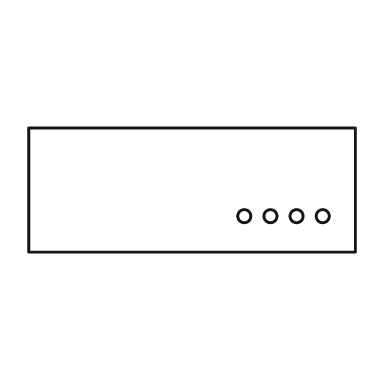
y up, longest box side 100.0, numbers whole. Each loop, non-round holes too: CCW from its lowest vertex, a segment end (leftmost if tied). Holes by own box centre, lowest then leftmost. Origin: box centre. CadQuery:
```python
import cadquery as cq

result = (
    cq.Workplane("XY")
    .moveTo(-50.0, -19.0)
    .lineTo(50.0, -19.0)
    .lineTo(50.0, 19.0)
    .lineTo(-50.0, 19.0)
    .close()
    .moveTo(16.0, -8.0)
    .circle(2.0)
    .moveTo(24.0, -8.0)
    .circle(2.0)
    .moveTo(32.0, -8.0)
    .circle(2.0)
    .moveTo(40.0, -8.0)
    .circle(2.0)
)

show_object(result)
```